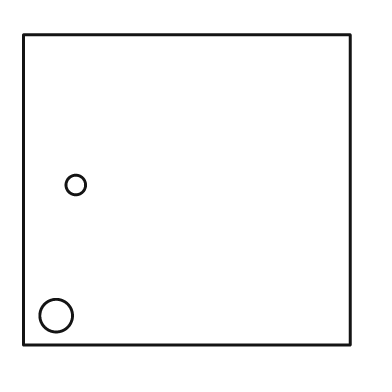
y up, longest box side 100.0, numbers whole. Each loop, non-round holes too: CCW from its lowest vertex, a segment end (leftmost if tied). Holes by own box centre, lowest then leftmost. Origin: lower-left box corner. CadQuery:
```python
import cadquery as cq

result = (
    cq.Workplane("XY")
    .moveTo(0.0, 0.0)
    .lineTo(100.0, 0.0)
    .lineTo(100.0, 95.0)
    .lineTo(0.0, 95.0)
    .close()
    .moveTo(10.0, 9.0)
    .circle(5.0)
    .moveTo(16.0, 49.0)
    .circle(3.0)
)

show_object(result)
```